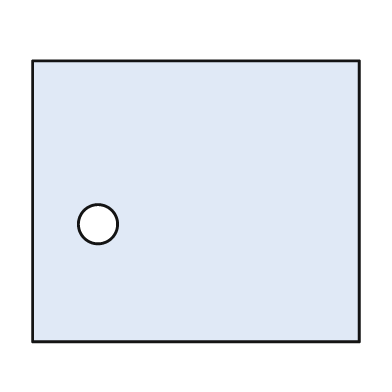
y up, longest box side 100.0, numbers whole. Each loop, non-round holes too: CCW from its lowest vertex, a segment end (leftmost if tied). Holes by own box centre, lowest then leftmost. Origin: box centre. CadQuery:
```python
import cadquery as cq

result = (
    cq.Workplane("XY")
    .moveTo(-50.0, -43.0)
    .lineTo(50.0, -43.0)
    .lineTo(50.0, 43.0)
    .lineTo(-50.0, 43.0)
    .close()
    .moveTo(-30.0, -7.0)
    .circle(6.0)
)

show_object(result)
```